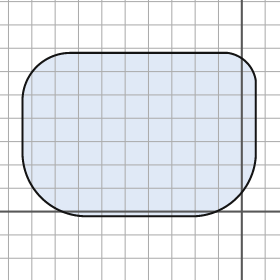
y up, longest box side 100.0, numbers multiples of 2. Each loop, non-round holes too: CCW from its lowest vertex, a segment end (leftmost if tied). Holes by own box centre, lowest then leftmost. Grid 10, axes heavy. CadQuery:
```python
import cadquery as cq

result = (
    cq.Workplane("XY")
    .moveTo(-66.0, -2.0)
    .lineTo(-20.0, -2.0)
    .threePointArc((-2.0, 6.0), (6.0, 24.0))
    .lineTo(6.0, 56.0)
    .threePointArc((2.0, 64.0), (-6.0, 68.0))
    .lineTo(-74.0, 68.0)
    .threePointArc((-88.0, 62.0), (-94.0, 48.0))
    .lineTo(-94.0, 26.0)
    .threePointArc((-86.0, 6.0), (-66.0, -2.0))
    .close()
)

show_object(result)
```